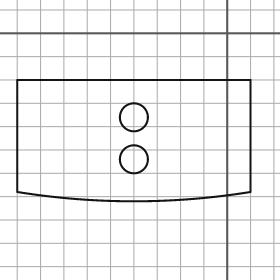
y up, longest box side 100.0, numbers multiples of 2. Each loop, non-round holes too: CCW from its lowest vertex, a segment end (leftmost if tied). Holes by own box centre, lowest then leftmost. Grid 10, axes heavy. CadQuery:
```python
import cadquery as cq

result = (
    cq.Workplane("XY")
    .moveTo(-90.0, -68.0)
    .threePointArc((-40.0, -72.0), (10.0, -68.0))
    .lineTo(10.0, -20.0)
    .lineTo(-90.0, -20.0)
    .close()
    .moveTo(-40.0, -54.0)
    .circle(6.0)
    .moveTo(-40.0, -36.0)
    .circle(6.0)
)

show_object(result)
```